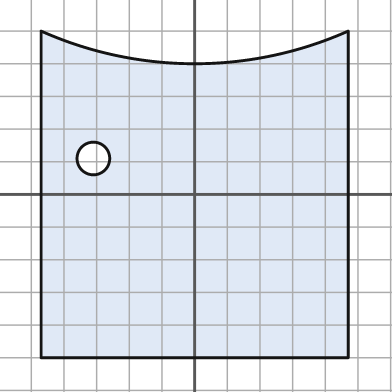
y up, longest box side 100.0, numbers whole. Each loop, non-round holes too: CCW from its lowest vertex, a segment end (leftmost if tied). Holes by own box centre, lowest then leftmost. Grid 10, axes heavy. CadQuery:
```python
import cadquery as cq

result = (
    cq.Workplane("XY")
    .moveTo(-47.0, -50.0)
    .lineTo(47.0, -50.0)
    .lineTo(47.0, 50.0)
    .threePointArc((0.0, 40.0), (-47.0, 50.0))
    .close()
    .moveTo(-31.0, 11.0)
    .circle(5.0)
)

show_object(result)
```